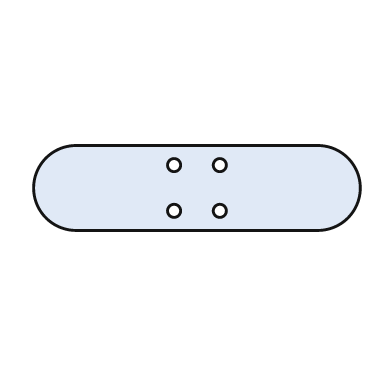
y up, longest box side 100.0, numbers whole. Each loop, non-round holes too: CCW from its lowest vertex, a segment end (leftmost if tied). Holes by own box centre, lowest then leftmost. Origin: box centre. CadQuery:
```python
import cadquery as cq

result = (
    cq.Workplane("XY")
    .moveTo(-37.0, -13.0)
    .lineTo(37.0, -13.0)
    .threePointArc((50.0, 0.0), (37.0, 13.0))
    .lineTo(-37.0, 13.0)
    .threePointArc((-50.0, 0.0), (-37.0, -13.0))
    .close()
    .moveTo(-7.0, -7.0)
    .circle(2.0)
    .moveTo(7.0, -7.0)
    .circle(2.0)
    .moveTo(-7.0, 7.0)
    .circle(2.0)
    .moveTo(7.0, 7.0)
    .circle(2.0)
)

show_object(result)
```